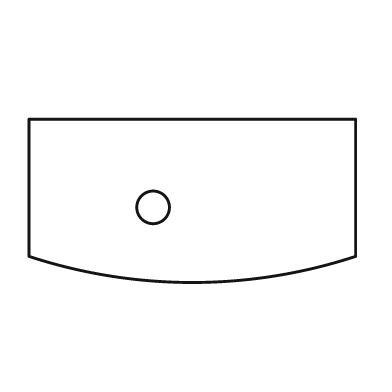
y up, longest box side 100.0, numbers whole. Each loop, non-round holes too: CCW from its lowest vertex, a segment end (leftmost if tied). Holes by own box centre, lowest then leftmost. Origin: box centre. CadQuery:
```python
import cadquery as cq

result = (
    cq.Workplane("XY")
    .moveTo(-50.0, -17.0)
    .threePointArc((0.0, -25.0), (50.0, -17.0))
    .lineTo(50.0, 25.0)
    .lineTo(-50.0, 25.0)
    .close()
    .moveTo(-12.0, -2.0)
    .circle(5.0)
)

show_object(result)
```